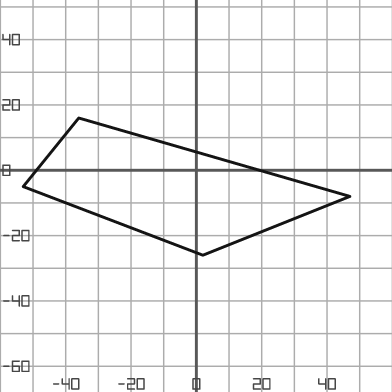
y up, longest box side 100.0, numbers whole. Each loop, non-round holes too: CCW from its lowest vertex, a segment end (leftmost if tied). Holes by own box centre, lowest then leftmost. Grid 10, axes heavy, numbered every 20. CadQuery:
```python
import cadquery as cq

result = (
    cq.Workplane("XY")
    .moveTo(2.0, -26.0)
    .lineTo(47.0, -8.0)
    .lineTo(-36.0, 16.0)
    .lineTo(-53.0, -5.0)
    .close()
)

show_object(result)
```